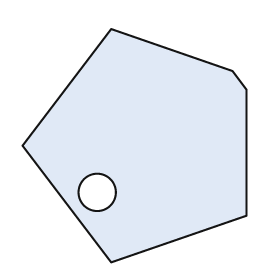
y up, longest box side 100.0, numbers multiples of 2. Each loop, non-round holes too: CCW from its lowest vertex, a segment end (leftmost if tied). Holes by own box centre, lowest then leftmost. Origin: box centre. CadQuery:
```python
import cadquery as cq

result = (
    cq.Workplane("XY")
    .moveTo(-10.0, -50.0)
    .lineTo(48.0, -30.0)
    .lineTo(48.0, 24.0)
    .lineTo(42.0, 32.0)
    .lineTo(-10.0, 50.0)
    .lineTo(-48.0, 0.0)
    .close()
    .moveTo(-16.0, -20.0)
    .circle(8.0)
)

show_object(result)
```